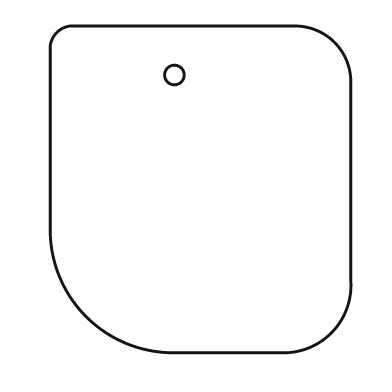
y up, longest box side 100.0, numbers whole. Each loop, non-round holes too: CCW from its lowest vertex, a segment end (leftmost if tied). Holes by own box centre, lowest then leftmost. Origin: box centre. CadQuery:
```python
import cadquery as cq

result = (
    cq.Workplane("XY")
    .moveTo(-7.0, -50.0)
    .lineTo(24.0, -50.0)
    .threePointArc((40.0, -44.0), (46.0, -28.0))
    .lineTo(46.0, 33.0)
    .threePointArc((41.0, 45.0), (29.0, 50.0))
    .lineTo(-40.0, 50.0)
    .threePointArc((-44.0, 48.0), (-46.0, 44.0))
    .lineTo(-46.0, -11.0)
    .threePointArc((-35.0, -39.0), (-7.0, -50.0))
    .close()
    .moveTo(-8.0, 35.0)
    .circle(3.0)
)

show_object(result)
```